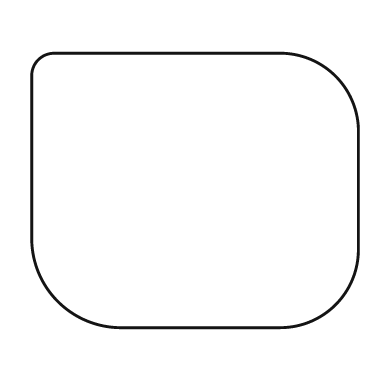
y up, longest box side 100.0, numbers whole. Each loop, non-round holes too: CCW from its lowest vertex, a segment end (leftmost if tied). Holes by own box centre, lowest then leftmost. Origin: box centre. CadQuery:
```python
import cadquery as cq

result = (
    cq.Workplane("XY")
    .moveTo(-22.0, -42.0)
    .lineTo(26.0, -42.0)
    .threePointArc((43.0, -35.0), (50.0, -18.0))
    .lineTo(50.0, 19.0)
    .threePointArc((43.0, 35.0), (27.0, 42.0))
    .lineTo(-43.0, 42.0)
    .threePointArc((-48.0, 40.0), (-50.0, 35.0))
    .lineTo(-50.0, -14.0)
    .threePointArc((-42.0, -34.0), (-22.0, -42.0))
    .close()
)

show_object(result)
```